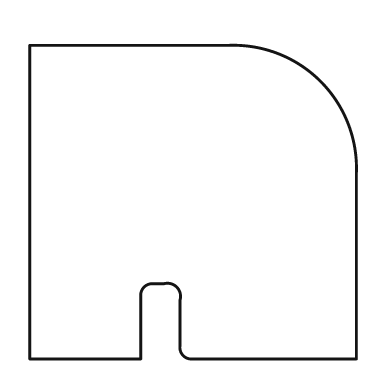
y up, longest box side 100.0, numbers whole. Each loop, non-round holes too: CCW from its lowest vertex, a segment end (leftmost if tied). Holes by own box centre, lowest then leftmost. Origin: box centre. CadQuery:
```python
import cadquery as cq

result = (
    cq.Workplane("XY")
    .moveTo(-50.0, -48.0)
    .lineTo(-16.0, -48.0)
    .lineTo(-16.0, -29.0)
    .threePointArc((-15.0, -26.0), (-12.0, -25.0))
    .lineTo(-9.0, -25.0)
    .threePointArc((-5.0, -26.0), (-4.0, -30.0))
    .lineTo(-4.0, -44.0)
    .threePointArc((-3.0, -47.0), (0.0, -48.0))
    .lineTo(50.0, -48.0)
    .lineTo(50.0, 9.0)
    .threePointArc((39.0, 37.0), (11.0, 48.0))
    .lineTo(-50.0, 48.0)
    .close()
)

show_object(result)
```